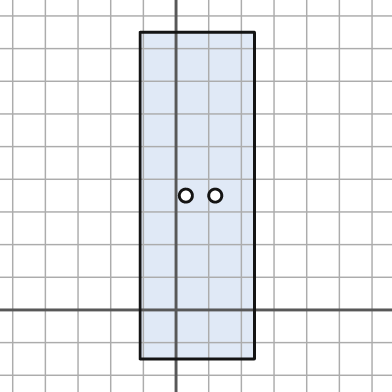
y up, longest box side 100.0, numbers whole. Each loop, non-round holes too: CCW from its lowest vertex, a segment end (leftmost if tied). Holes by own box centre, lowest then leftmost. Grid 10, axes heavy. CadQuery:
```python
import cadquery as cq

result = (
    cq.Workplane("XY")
    .moveTo(-11.0, -15.0)
    .lineTo(24.0, -15.0)
    .lineTo(24.0, 85.0)
    .lineTo(-11.0, 85.0)
    .close()
    .moveTo(3.0, 35.0)
    .circle(2.0)
    .moveTo(12.0, 35.0)
    .circle(2.0)
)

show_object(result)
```